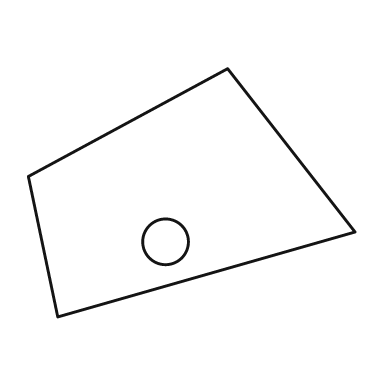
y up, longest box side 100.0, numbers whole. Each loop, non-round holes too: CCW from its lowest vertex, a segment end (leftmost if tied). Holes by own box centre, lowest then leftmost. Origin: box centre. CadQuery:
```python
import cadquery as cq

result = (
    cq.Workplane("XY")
    .moveTo(-41.0, -38.0)
    .lineTo(50.0, -12.0)
    .lineTo(11.0, 38.0)
    .lineTo(-50.0, 5.0)
    .close()
    .moveTo(-8.0, -15.0)
    .circle(7.0)
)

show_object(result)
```